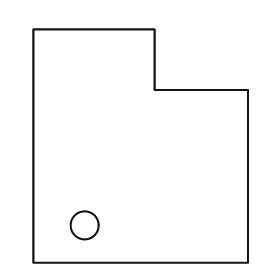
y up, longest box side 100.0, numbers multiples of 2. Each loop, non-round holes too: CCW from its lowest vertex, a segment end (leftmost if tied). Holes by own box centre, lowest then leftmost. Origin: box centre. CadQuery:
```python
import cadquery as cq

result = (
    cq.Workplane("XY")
    .moveTo(-46.0, -50.0)
    .lineTo(46.0, -50.0)
    .lineTo(46.0, 24.0)
    .lineTo(6.0, 24.0)
    .lineTo(6.0, 50.0)
    .lineTo(-46.0, 50.0)
    .close()
    .moveTo(-24.0, -34.0)
    .circle(6.0)
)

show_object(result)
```